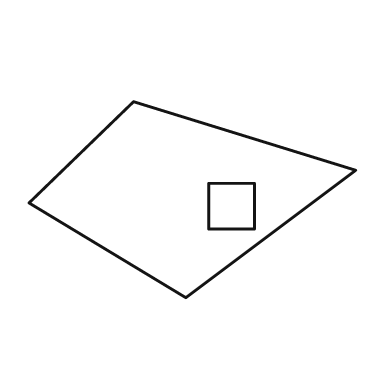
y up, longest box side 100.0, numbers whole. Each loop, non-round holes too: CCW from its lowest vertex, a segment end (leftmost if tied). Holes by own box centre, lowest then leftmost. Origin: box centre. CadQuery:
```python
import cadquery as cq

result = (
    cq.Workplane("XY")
    .moveTo(-2.0, -30.0)
    .lineTo(50.0, 9.0)
    .lineTo(-18.0, 30.0)
    .lineTo(-50.0, -1.0)
    .close()
    .moveTo(5.0, -9.0)
    .lineTo(19.0, -9.0)
    .lineTo(19.0, 5.0)
    .lineTo(5.0, 5.0)
    .close()
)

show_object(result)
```